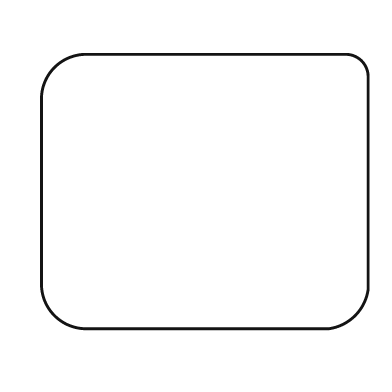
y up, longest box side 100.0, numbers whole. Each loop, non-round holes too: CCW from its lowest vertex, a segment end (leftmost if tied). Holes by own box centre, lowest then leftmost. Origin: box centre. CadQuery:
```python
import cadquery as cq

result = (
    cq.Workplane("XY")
    .moveTo(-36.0, -42.0)
    .lineTo(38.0, -42.0)
    .threePointArc((46.0, -38.0), (50.0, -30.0))
    .lineTo(50.0, 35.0)
    .threePointArc((48.0, 40.0), (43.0, 42.0))
    .lineTo(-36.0, 42.0)
    .threePointArc((-46.0, 38.0), (-50.0, 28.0))
    .lineTo(-50.0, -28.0)
    .threePointArc((-46.0, -38.0), (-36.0, -42.0))
    .close()
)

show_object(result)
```